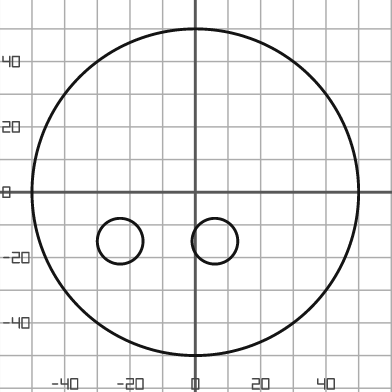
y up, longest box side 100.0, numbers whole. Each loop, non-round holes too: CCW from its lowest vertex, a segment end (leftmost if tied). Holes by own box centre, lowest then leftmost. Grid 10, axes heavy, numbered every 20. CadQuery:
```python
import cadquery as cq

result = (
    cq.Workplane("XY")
    .moveTo(0.0, 0.0)
    .circle(50.0)
    .moveTo(-23.0, -15.0)
    .circle(7.0)
    .moveTo(6.0, -15.0)
    .circle(7.0)
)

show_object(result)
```